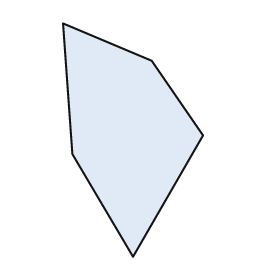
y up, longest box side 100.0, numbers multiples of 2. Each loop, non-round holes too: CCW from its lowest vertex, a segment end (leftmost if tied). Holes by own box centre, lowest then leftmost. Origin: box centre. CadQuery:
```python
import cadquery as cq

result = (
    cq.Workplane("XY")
    .moveTo(0.0, -50.0)
    .lineTo(30.0, 2.0)
    .lineTo(8.0, 34.0)
    .lineTo(-30.0, 50.0)
    .lineTo(-26.0, -6.0)
    .close()
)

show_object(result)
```